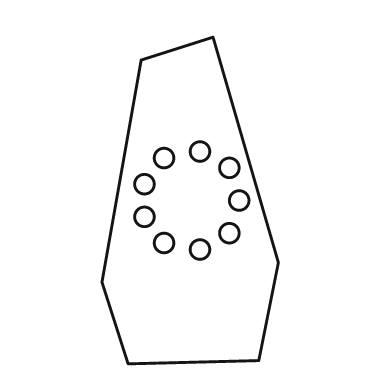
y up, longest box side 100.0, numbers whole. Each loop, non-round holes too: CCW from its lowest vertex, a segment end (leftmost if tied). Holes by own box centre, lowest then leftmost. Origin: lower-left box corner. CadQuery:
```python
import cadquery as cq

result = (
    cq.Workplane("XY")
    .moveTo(8.0, 0.0)
    .lineTo(48.0, 1.0)
    .lineTo(54.0, 31.0)
    .lineTo(34.0, 100.0)
    .lineTo(12.0, 93.0)
    .lineTo(0.0, 25.0)
    .close()
    .moveTo(30.0, 35.0)
    .circle(3.0)
    .moveTo(19.0, 37.0)
    .circle(3.0)
    .moveTo(39.0, 40.0)
    .circle(3.0)
    .moveTo(13.0, 45.0)
    .circle(3.0)
    .moveTo(42.0, 50.0)
    .circle(3.0)
    .moveTo(13.0, 55.0)
    .circle(3.0)
    .moveTo(39.0, 60.0)
    .circle(3.0)
    .moveTo(19.0, 63.0)
    .circle(3.0)
    .moveTo(30.0, 65.0)
    .circle(3.0)
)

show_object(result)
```